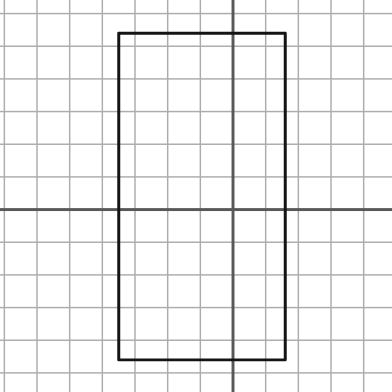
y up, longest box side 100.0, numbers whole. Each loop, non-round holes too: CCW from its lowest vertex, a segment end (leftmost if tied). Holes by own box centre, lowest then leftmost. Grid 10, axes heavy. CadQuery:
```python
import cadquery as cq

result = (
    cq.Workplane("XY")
    .moveTo(-35.0, -46.0)
    .lineTo(16.0, -46.0)
    .lineTo(16.0, 54.0)
    .lineTo(-35.0, 54.0)
    .close()
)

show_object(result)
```